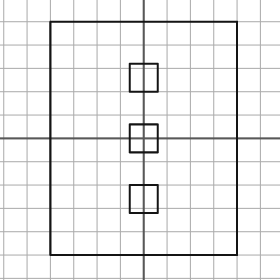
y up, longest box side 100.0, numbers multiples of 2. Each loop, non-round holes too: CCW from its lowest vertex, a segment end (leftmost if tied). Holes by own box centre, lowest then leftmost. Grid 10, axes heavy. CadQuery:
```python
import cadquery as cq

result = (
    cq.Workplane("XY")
    .moveTo(-40.0, -50.0)
    .lineTo(40.0, -50.0)
    .lineTo(40.0, 50.0)
    .lineTo(-40.0, 50.0)
    .close()
    .moveTo(-6.0, -32.0)
    .lineTo(6.0, -32.0)
    .lineTo(6.0, -20.0)
    .lineTo(-6.0, -20.0)
    .close()
    .moveTo(-6.0, -6.0)
    .lineTo(6.0, -6.0)
    .lineTo(6.0, 6.0)
    .lineTo(-6.0, 6.0)
    .close()
    .moveTo(-6.0, 20.0)
    .lineTo(6.0, 20.0)
    .lineTo(6.0, 32.0)
    .lineTo(-6.0, 32.0)
    .close()
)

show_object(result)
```